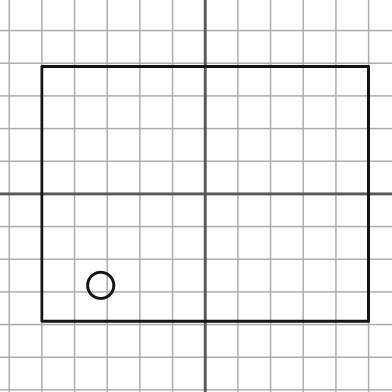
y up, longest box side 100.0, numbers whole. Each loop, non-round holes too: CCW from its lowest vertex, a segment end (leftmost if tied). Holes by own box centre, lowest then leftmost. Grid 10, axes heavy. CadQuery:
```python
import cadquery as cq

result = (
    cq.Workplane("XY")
    .moveTo(-50.0, -39.0)
    .lineTo(50.0, -39.0)
    .lineTo(50.0, 39.0)
    .lineTo(-50.0, 39.0)
    .close()
    .moveTo(-32.0, -28.0)
    .circle(4.0)
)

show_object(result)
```